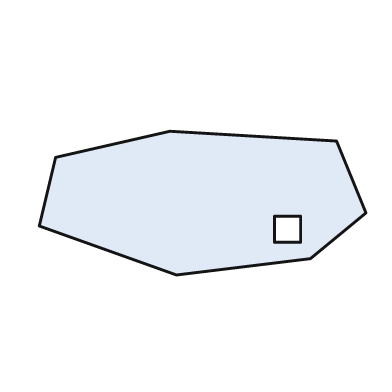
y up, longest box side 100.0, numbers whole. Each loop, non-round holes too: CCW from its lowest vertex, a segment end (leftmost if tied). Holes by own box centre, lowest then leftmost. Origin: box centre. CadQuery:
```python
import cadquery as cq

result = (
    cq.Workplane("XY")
    .moveTo(-8.0, -22.0)
    .lineTo(33.0, -17.0)
    .lineTo(50.0, -3.0)
    .lineTo(41.0, 19.0)
    .lineTo(-10.0, 22.0)
    .lineTo(-45.0, 14.0)
    .lineTo(-50.0, -7.0)
    .close()
    .moveTo(22.0, -12.0)
    .lineTo(30.0, -12.0)
    .lineTo(30.0, -4.0)
    .lineTo(22.0, -4.0)
    .close()
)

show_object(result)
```